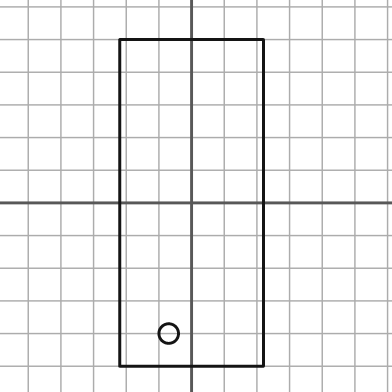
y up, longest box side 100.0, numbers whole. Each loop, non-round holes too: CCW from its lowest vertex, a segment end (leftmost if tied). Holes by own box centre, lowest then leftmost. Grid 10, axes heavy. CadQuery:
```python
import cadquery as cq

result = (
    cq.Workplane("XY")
    .moveTo(-22.0, -50.0)
    .lineTo(22.0, -50.0)
    .lineTo(22.0, 50.0)
    .lineTo(-22.0, 50.0)
    .close()
    .moveTo(-7.0, -40.0)
    .circle(3.0)
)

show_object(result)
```